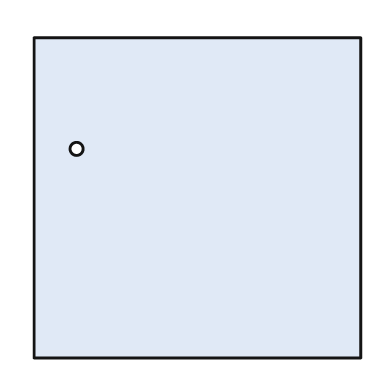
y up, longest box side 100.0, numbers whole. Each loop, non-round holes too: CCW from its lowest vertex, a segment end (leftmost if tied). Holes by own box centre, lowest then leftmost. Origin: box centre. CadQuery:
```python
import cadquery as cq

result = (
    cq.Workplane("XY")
    .moveTo(-50.0, -49.0)
    .lineTo(50.0, -49.0)
    .lineTo(50.0, 49.0)
    .lineTo(-50.0, 49.0)
    .close()
    .moveTo(-37.0, 15.0)
    .circle(2.0)
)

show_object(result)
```